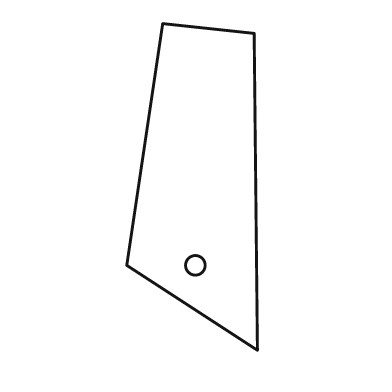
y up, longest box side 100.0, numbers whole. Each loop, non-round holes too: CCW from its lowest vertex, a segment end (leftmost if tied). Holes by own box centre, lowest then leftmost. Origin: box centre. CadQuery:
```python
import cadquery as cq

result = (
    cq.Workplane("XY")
    .moveTo(20.0, -50.0)
    .lineTo(19.0, 47.0)
    .lineTo(-9.0, 50.0)
    .lineTo(-20.0, -24.0)
    .close()
    .moveTo(1.0, -24.0)
    .circle(3.0)
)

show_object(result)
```